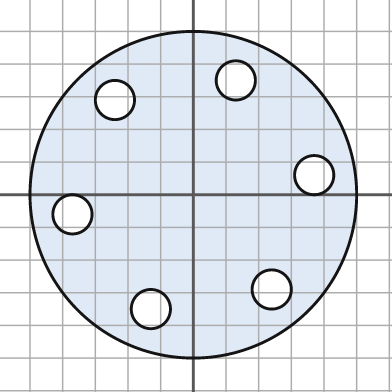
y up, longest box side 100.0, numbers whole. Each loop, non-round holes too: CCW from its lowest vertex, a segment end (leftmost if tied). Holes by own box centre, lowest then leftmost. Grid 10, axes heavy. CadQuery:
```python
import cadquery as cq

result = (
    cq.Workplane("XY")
    .moveTo(0.0, 0.0)
    .circle(50.0)
    .moveTo(-13.0, -35.0)
    .circle(6.0)
    .moveTo(24.0, -29.0)
    .circle(6.0)
    .moveTo(-37.0, -6.0)
    .circle(6.0)
    .moveTo(37.0, 6.0)
    .circle(6.0)
    .moveTo(-24.0, 29.0)
    .circle(6.0)
    .moveTo(13.0, 35.0)
    .circle(6.0)
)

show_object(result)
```